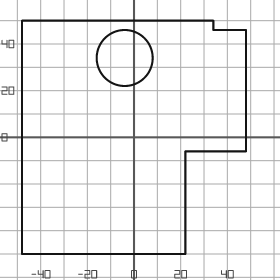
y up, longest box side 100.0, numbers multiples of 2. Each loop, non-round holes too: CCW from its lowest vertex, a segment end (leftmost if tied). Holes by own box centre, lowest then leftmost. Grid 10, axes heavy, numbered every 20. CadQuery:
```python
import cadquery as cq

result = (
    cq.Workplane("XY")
    .moveTo(-48.0, -50.0)
    .lineTo(22.0, -50.0)
    .lineTo(22.0, -6.0)
    .lineTo(48.0, -6.0)
    .lineTo(48.0, 46.0)
    .lineTo(34.0, 46.0)
    .lineTo(34.0, 50.0)
    .lineTo(-48.0, 50.0)
    .close()
    .moveTo(-4.0, 34.0)
    .circle(12.0)
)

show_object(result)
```